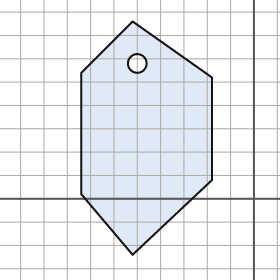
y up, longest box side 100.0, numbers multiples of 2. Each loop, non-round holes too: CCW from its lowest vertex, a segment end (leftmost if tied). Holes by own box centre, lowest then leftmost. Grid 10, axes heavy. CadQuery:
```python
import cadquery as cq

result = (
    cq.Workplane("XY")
    .moveTo(-52.0, -24.0)
    .lineTo(-18.0, 8.0)
    .lineTo(-18.0, 52.0)
    .lineTo(-52.0, 76.0)
    .lineTo(-74.0, 54.0)
    .lineTo(-74.0, 2.0)
    .close()
    .moveTo(-50.0, 58.0)
    .circle(4.0)
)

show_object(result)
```